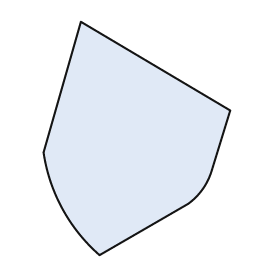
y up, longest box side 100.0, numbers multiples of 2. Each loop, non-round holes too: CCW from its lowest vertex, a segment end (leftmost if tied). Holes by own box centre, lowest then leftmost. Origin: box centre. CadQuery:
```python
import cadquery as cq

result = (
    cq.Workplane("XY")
    .moveTo(-16.0, -50.0)
    .lineTo(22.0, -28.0)
    .threePointArc((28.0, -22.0), (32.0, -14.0))
    .lineTo(40.0, 12.0)
    .lineTo(-24.0, 50.0)
    .lineTo(-40.0, -6.0)
    .threePointArc((-32.0, -30.0), (-16.0, -50.0))
    .close()
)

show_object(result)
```